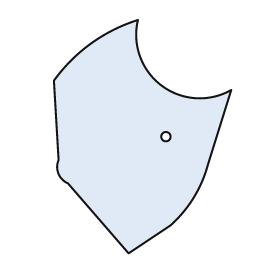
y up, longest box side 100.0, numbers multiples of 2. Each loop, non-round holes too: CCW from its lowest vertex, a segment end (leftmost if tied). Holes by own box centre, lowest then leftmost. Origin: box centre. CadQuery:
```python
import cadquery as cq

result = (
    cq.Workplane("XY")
    .moveTo(-6.0, -50.0)
    .lineTo(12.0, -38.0)
    .threePointArc((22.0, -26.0), (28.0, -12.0))
    .lineTo(38.0, 20.0)
    .threePointArc((8.0, 22.0), (-2.0, 50.0))
    .threePointArc((-22.0, 40.0), (-38.0, 24.0))
    .lineTo(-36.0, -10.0)
    .threePointArc((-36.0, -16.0), (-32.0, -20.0))
    .close()
    .moveTo(10.0, 0.0)
    .circle(2.0)
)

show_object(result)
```